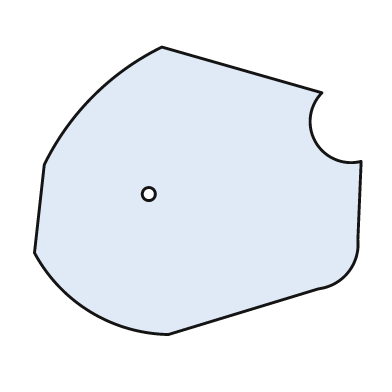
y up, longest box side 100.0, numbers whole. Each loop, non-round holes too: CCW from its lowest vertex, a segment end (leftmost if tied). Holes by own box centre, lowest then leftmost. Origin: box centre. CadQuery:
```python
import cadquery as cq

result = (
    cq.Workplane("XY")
    .moveTo(-9.0, -44.0)
    .lineTo(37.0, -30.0)
    .threePointArc((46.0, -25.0), (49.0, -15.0))
    .lineTo(50.0, 9.0)
    .threePointArc((36.0, 15.0), (38.0, 30.0))
    .lineTo(-11.0, 44.0)
    .threePointArc((-32.0, 29.0), (-47.0, 8.0))
    .lineTo(-50.0, -19.0)
    .threePointArc((-33.0, -37.0), (-9.0, -44.0))
    .close()
    .moveTo(-15.0, -1.0)
    .circle(2.0)
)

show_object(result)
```